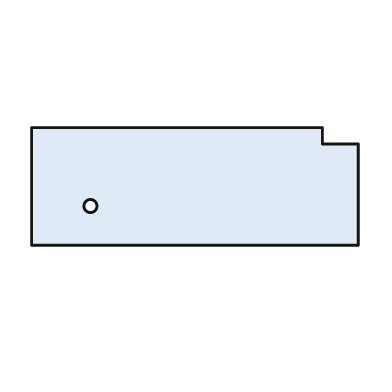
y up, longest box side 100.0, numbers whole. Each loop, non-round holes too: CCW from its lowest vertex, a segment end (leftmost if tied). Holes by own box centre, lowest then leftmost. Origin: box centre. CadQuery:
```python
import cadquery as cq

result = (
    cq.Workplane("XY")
    .moveTo(-50.0, -18.0)
    .lineTo(50.0, -18.0)
    .lineTo(50.0, 13.0)
    .lineTo(39.0, 13.0)
    .lineTo(39.0, 18.0)
    .lineTo(-50.0, 18.0)
    .close()
    .moveTo(-32.0, -6.0)
    .circle(2.0)
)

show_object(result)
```